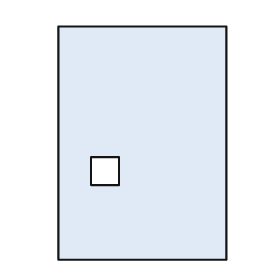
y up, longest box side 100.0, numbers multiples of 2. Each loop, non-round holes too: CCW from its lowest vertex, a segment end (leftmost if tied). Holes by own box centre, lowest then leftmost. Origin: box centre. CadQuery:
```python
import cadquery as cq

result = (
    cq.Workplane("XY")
    .moveTo(-36.0, -50.0)
    .lineTo(36.0, -50.0)
    .lineTo(36.0, 50.0)
    .lineTo(-36.0, 50.0)
    .close()
    .moveTo(-22.0, -18.0)
    .lineTo(-10.0, -18.0)
    .lineTo(-10.0, -6.0)
    .lineTo(-22.0, -6.0)
    .close()
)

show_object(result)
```